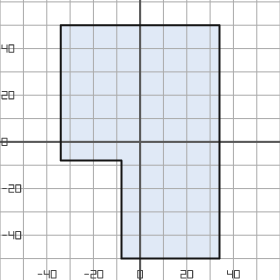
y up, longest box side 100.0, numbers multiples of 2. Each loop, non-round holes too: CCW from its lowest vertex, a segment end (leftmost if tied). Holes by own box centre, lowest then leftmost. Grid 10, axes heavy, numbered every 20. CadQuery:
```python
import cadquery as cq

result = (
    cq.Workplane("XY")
    .moveTo(-8.0, -50.0)
    .lineTo(34.0, -50.0)
    .lineTo(34.0, 50.0)
    .lineTo(-34.0, 50.0)
    .lineTo(-34.0, -8.0)
    .lineTo(-8.0, -8.0)
    .close()
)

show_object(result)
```